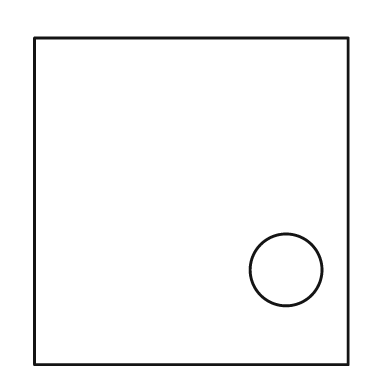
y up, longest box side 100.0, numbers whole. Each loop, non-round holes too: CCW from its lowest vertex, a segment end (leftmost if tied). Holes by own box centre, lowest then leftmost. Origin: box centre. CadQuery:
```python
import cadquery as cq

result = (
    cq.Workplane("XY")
    .moveTo(-48.0, -50.0)
    .lineTo(48.0, -50.0)
    .lineTo(48.0, 50.0)
    .lineTo(-48.0, 50.0)
    .close()
    .moveTo(29.0, -21.0)
    .circle(11.0)
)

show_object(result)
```